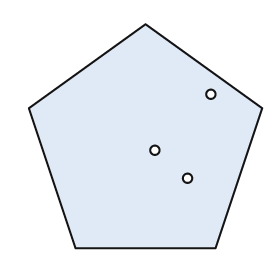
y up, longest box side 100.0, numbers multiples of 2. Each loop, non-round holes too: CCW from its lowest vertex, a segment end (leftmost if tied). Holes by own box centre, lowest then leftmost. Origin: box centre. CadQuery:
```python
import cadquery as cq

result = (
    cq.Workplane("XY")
    .moveTo(-30.0, -48.0)
    .lineTo(30.0, -48.0)
    .lineTo(50.0, 12.0)
    .lineTo(0.0, 48.0)
    .lineTo(-50.0, 12.0)
    .close()
    .moveTo(18.0, -18.0)
    .circle(2.0)
    .moveTo(4.0, -6.0)
    .circle(2.0)
    .moveTo(28.0, 18.0)
    .circle(2.0)
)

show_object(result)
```